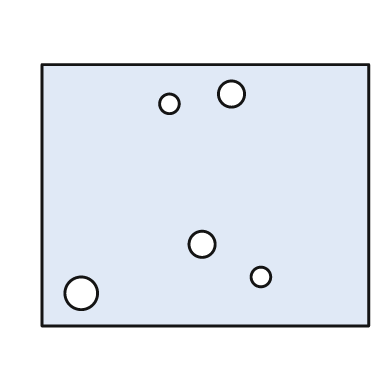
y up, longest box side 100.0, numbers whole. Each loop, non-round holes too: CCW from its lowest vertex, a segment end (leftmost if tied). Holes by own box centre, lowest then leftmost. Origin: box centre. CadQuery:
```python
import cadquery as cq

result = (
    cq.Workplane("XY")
    .moveTo(-50.0, -40.0)
    .lineTo(50.0, -40.0)
    .lineTo(50.0, 40.0)
    .lineTo(-50.0, 40.0)
    .close()
    .moveTo(-38.0, -30.0)
    .circle(5.0)
    .moveTo(17.0, -25.0)
    .circle(3.0)
    .moveTo(-1.0, -15.0)
    .circle(4.0)
    .moveTo(-11.0, 28.0)
    .circle(3.0)
    .moveTo(8.0, 31.0)
    .circle(4.0)
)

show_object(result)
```